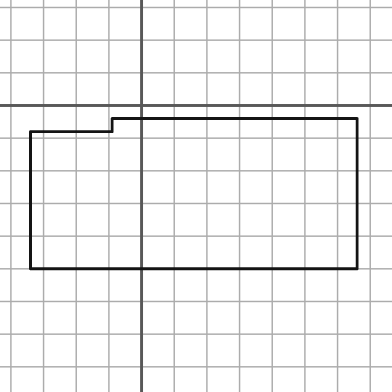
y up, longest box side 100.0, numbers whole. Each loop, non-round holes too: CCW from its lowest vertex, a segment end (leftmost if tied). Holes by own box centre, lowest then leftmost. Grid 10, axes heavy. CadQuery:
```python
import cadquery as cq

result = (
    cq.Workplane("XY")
    .moveTo(-34.0, -50.0)
    .lineTo(66.0, -50.0)
    .lineTo(66.0, -4.0)
    .lineTo(-9.0, -4.0)
    .lineTo(-9.0, -8.0)
    .lineTo(-34.0, -8.0)
    .close()
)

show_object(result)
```